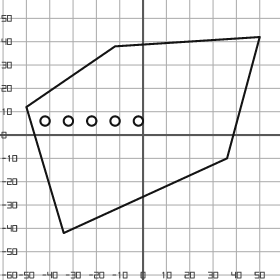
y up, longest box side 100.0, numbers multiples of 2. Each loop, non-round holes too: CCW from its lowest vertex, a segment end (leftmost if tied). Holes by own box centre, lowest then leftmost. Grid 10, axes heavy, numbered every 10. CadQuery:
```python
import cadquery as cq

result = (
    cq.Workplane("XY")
    .moveTo(-34.0, -42.0)
    .lineTo(36.0, -10.0)
    .lineTo(50.0, 42.0)
    .lineTo(-12.0, 38.0)
    .lineTo(-50.0, 12.0)
    .close()
    .moveTo(-42.0, 6.0)
    .circle(2.0)
    .moveTo(-32.0, 6.0)
    .circle(2.0)
    .moveTo(-22.0, 6.0)
    .circle(2.0)
    .moveTo(-12.0, 6.0)
    .circle(2.0)
    .moveTo(-2.0, 6.0)
    .circle(2.0)
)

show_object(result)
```